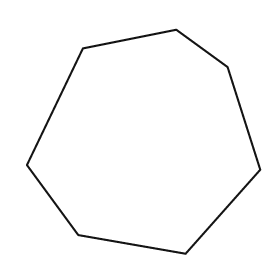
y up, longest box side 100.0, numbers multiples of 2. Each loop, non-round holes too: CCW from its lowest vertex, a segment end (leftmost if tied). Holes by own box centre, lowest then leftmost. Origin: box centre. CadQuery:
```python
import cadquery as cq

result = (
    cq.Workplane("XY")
    .moveTo(18.0, -48.0)
    .lineTo(50.0, -12.0)
    .lineTo(36.0, 32.0)
    .lineTo(14.0, 48.0)
    .lineTo(-26.0, 40.0)
    .lineTo(-50.0, -10.0)
    .lineTo(-28.0, -40.0)
    .close()
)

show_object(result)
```